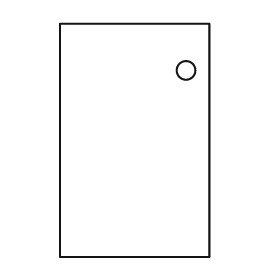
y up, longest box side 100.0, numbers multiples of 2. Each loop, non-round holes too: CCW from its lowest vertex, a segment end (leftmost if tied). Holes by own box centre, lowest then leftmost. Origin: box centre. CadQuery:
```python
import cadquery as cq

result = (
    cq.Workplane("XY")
    .moveTo(-32.0, -50.0)
    .lineTo(32.0, -50.0)
    .lineTo(32.0, 50.0)
    .lineTo(-32.0, 50.0)
    .close()
    .moveTo(22.0, 30.0)
    .circle(4.0)
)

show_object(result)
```